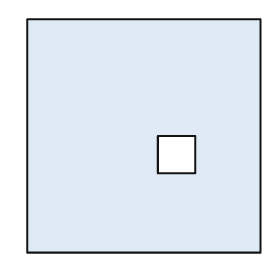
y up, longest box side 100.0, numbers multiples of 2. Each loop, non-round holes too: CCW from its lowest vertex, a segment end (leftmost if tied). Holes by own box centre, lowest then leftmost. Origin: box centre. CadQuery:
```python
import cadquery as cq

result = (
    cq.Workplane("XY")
    .moveTo(-50.0, -50.0)
    .lineTo(50.0, -50.0)
    .lineTo(50.0, 50.0)
    .lineTo(-50.0, 50.0)
    .close()
    .moveTo(6.0, -16.0)
    .lineTo(22.0, -16.0)
    .lineTo(22.0, 0.0)
    .lineTo(6.0, 0.0)
    .close()
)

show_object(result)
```